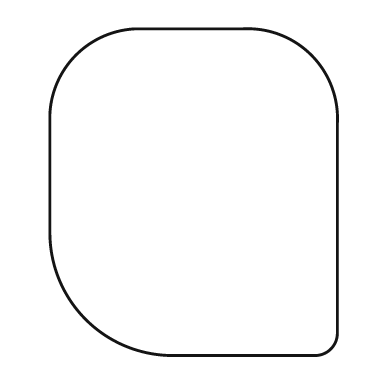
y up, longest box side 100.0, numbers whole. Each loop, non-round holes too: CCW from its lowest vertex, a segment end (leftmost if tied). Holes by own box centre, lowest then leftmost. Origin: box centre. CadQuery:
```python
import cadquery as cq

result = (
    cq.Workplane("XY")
    .moveTo(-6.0, -50.0)
    .lineTo(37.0, -50.0)
    .threePointArc((42.0, -48.0), (44.0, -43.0))
    .lineTo(44.0, 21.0)
    .threePointArc((36.0, 42.0), (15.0, 50.0))
    .lineTo(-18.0, 50.0)
    .threePointArc((-36.0, 42.0), (-44.0, 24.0))
    .lineTo(-44.0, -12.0)
    .threePointArc((-33.0, -39.0), (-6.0, -50.0))
    .close()
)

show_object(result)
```